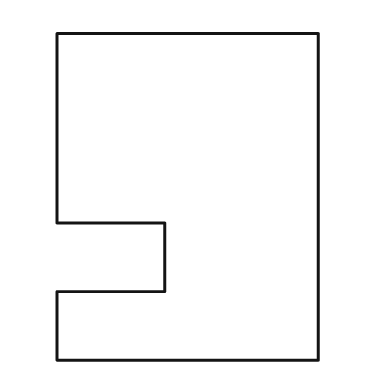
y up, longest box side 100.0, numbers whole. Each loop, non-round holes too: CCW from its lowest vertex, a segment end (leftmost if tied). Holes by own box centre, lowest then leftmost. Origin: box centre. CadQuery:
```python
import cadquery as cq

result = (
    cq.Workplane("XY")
    .moveTo(-40.0, -50.0)
    .lineTo(40.0, -50.0)
    .lineTo(40.0, 50.0)
    .lineTo(-40.0, 50.0)
    .lineTo(-40.0, -8.0)
    .lineTo(-7.0, -8.0)
    .lineTo(-7.0, -29.0)
    .lineTo(-40.0, -29.0)
    .close()
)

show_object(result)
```